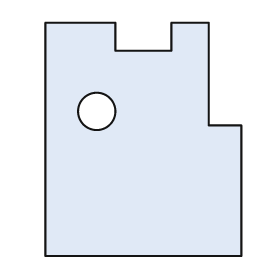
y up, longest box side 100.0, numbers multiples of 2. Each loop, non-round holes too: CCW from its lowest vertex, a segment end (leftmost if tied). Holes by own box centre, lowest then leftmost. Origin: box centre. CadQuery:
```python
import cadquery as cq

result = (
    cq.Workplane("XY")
    .moveTo(-42.0, -50.0)
    .lineTo(42.0, -50.0)
    .lineTo(42.0, 6.0)
    .lineTo(28.0, 6.0)
    .lineTo(28.0, 50.0)
    .lineTo(12.0, 50.0)
    .lineTo(12.0, 38.0)
    .lineTo(-12.0, 38.0)
    .lineTo(-12.0, 50.0)
    .lineTo(-42.0, 50.0)
    .close()
    .moveTo(-20.0, 12.0)
    .circle(8.0)
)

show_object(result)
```